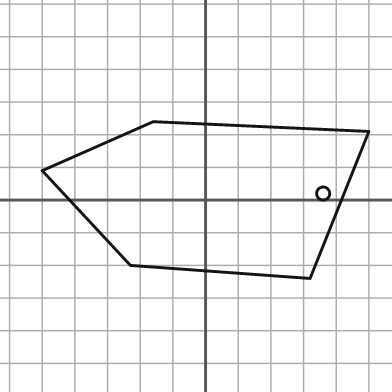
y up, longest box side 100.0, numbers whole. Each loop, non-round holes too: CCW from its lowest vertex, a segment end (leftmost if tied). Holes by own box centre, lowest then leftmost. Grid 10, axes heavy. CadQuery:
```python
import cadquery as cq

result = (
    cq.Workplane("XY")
    .moveTo(32.0, -24.0)
    .lineTo(50.0, 21.0)
    .lineTo(-16.0, 24.0)
    .lineTo(-50.0, 9.0)
    .lineTo(-23.0, -20.0)
    .close()
    .moveTo(36.0, 2.0)
    .circle(2.0)
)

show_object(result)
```